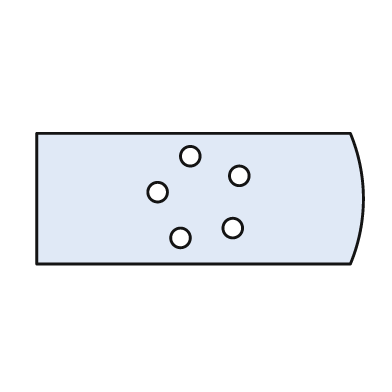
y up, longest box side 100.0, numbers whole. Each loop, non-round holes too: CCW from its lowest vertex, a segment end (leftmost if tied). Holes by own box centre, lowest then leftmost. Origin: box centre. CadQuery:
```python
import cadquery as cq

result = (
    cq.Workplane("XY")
    .moveTo(-50.0, -20.0)
    .lineTo(46.0, -20.0)
    .threePointArc((50.0, 0.0), (46.0, 20.0))
    .lineTo(-50.0, 20.0)
    .close()
    .moveTo(-6.0, -12.0)
    .circle(3.0)
    .moveTo(10.0, -9.0)
    .circle(3.0)
    .moveTo(-13.0, 2.0)
    .circle(3.0)
    .moveTo(12.0, 7.0)
    .circle(3.0)
    .moveTo(-3.0, 13.0)
    .circle(3.0)
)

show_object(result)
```